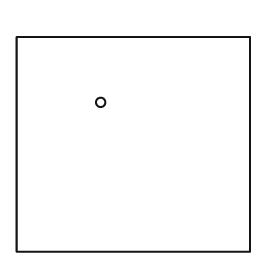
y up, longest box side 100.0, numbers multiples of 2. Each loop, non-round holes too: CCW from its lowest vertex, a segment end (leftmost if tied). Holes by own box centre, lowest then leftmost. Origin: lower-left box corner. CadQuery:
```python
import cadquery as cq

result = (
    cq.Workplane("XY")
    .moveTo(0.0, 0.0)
    .lineTo(100.0, 0.0)
    .lineTo(100.0, 92.0)
    .lineTo(0.0, 92.0)
    .close()
    .moveTo(36.0, 64.0)
    .circle(2.0)
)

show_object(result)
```